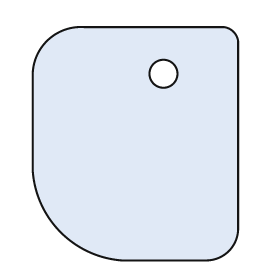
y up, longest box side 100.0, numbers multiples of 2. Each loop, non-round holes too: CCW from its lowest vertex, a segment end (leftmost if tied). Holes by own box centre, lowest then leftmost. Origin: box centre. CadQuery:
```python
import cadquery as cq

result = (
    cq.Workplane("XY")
    .moveTo(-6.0, -50.0)
    .lineTo(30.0, -50.0)
    .threePointArc((40.0, -46.0), (44.0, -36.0))
    .lineTo(44.0, 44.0)
    .threePointArc((42.0, 48.0), (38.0, 50.0))
    .lineTo(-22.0, 50.0)
    .threePointArc((-38.0, 44.0), (-44.0, 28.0))
    .lineTo(-44.0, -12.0)
    .threePointArc((-32.0, -38.0), (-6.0, -50.0))
    .close()
    .moveTo(12.0, 30.0)
    .circle(6.0)
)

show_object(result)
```